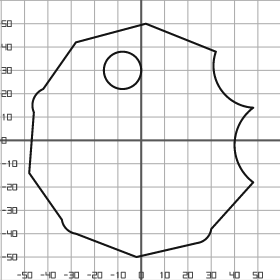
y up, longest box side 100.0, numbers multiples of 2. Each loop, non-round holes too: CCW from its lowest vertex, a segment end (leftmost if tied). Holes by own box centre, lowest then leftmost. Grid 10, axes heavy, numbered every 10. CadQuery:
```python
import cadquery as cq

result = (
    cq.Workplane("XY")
    .moveTo(-2.0, -50.0)
    .lineTo(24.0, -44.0)
    .threePointArc((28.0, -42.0), (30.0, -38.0))
    .lineTo(48.0, -18.0)
    .threePointArc((40.0, -2.0), (48.0, 14.0))
    .threePointArc((34.0, 22.0), (32.0, 38.0))
    .lineTo(2.0, 50.0)
    .lineTo(-28.0, 42.0)
    .lineTo(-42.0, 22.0)
    .threePointArc((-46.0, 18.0), (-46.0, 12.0))
    .lineTo(-48.0, -14.0)
    .lineTo(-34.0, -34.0)
    .threePointArc((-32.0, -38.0), (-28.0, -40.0))
    .close()
    .moveTo(-8.0, 30.0)
    .circle(8.0)
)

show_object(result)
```